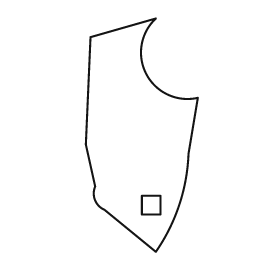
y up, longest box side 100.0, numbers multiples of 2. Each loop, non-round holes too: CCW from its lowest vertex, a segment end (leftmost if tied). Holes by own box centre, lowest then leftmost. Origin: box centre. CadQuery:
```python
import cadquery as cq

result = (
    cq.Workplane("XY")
    .moveTo(6.0, -50.0)
    .threePointArc((16.0, -30.0), (20.0, -8.0))
    .lineTo(24.0, 16.0)
    .threePointArc((2.0, 26.0), (6.0, 50.0))
    .lineTo(-22.0, 42.0)
    .lineTo(-24.0, -4.0)
    .lineTo(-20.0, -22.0)
    .threePointArc((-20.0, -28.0), (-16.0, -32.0))
    .close()
    .moveTo(0.0, -34.0)
    .lineTo(8.0, -34.0)
    .lineTo(8.0, -26.0)
    .lineTo(0.0, -26.0)
    .close()
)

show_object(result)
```